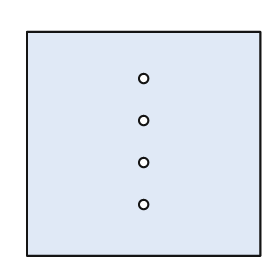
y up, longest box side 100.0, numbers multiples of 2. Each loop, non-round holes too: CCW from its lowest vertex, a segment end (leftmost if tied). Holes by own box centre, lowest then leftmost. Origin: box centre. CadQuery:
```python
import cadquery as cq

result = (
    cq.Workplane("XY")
    .moveTo(-50.0, -48.0)
    .lineTo(50.0, -48.0)
    .lineTo(50.0, 48.0)
    .lineTo(-50.0, 48.0)
    .close()
    .moveTo(0.0, -26.0)
    .circle(2.0)
    .moveTo(0.0, -8.0)
    .circle(2.0)
    .moveTo(0.0, 10.0)
    .circle(2.0)
    .moveTo(0.0, 28.0)
    .circle(2.0)
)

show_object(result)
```